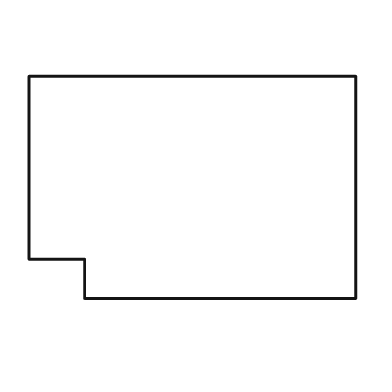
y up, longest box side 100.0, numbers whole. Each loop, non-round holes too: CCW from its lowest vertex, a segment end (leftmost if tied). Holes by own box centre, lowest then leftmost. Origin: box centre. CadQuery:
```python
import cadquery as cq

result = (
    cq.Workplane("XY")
    .moveTo(-33.0, -34.0)
    .lineTo(50.0, -34.0)
    .lineTo(50.0, 34.0)
    .lineTo(-50.0, 34.0)
    .lineTo(-50.0, -22.0)
    .lineTo(-33.0, -22.0)
    .close()
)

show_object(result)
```